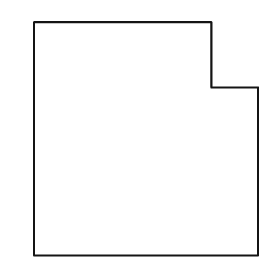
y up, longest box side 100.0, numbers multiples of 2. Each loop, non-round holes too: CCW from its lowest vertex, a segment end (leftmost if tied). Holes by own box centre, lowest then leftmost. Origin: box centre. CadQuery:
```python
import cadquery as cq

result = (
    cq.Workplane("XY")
    .moveTo(-48.0, -50.0)
    .lineTo(48.0, -50.0)
    .lineTo(48.0, 22.0)
    .lineTo(28.0, 22.0)
    .lineTo(28.0, 50.0)
    .lineTo(-48.0, 50.0)
    .close()
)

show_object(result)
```